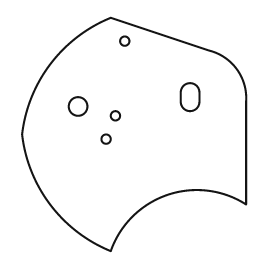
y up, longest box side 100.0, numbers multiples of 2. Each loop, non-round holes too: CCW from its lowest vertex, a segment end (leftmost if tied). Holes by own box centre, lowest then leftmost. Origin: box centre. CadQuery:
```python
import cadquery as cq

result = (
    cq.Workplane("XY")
    .moveTo(-10.0, -50.0)
    .threePointArc((14.0, -26.0), (48.0, -30.0))
    .lineTo(48.0, 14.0)
    .threePointArc((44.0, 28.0), (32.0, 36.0))
    .lineTo(-10.0, 50.0)
    .threePointArc((-36.0, 30.0), (-48.0, 0.0))
    .threePointArc((-36.0, -30.0), (-10.0, -50.0))
    .close()
    .moveTo(-12.0, -2.0)
    .circle(2.0)
    .moveTo(-8.0, 8.0)
    .circle(2.0)
    .moveTo(-24.0, 12.0)
    .circle(4.0)
    .moveTo(20.0, 14.0)
    .threePointArc((24.0, 10.0), (28.0, 14.0))
    .lineTo(28.0, 18.0)
    .threePointArc((24.0, 22.0), (20.0, 18.0))
    .close()
    .moveTo(-4.0, 40.0)
    .circle(2.0)
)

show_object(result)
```